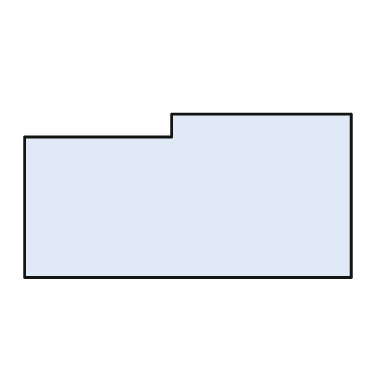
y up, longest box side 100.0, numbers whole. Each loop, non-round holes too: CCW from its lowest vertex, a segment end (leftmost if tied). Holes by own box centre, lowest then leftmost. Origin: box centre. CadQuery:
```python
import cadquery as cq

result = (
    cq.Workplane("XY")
    .moveTo(-50.0, -25.0)
    .lineTo(50.0, -25.0)
    .lineTo(50.0, 25.0)
    .lineTo(-5.0, 25.0)
    .lineTo(-5.0, 18.0)
    .lineTo(-50.0, 18.0)
    .close()
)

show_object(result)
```